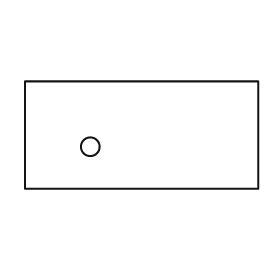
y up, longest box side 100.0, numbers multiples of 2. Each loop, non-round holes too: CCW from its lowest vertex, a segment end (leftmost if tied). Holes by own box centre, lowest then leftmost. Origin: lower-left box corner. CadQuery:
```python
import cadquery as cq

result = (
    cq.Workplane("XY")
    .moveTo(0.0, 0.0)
    .lineTo(100.0, 0.0)
    .lineTo(100.0, 46.0)
    .lineTo(0.0, 46.0)
    .close()
    .moveTo(28.0, 18.0)
    .circle(4.0)
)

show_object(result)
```